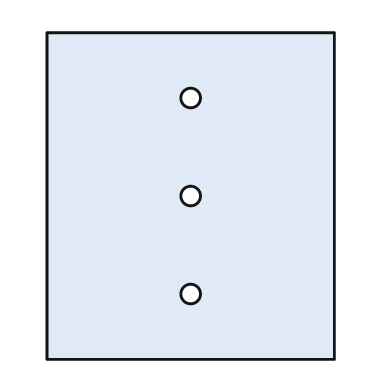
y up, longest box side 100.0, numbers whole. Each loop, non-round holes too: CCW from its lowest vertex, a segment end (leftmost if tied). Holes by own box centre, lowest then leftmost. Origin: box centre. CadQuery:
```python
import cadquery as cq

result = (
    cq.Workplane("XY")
    .moveTo(-44.0, -50.0)
    .lineTo(44.0, -50.0)
    .lineTo(44.0, 50.0)
    .lineTo(-44.0, 50.0)
    .close()
    .moveTo(0.0, -30.0)
    .circle(3.0)
    .moveTo(0.0, 0.0)
    .circle(3.0)
    .moveTo(0.0, 30.0)
    .circle(3.0)
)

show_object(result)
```